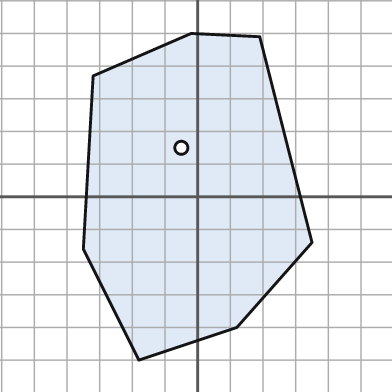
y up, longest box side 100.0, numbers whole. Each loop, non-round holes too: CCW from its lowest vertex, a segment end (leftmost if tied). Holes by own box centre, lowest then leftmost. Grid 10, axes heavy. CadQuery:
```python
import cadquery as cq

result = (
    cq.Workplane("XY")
    .moveTo(-18.0, -50.0)
    .lineTo(12.0, -40.0)
    .lineTo(35.0, -14.0)
    .lineTo(19.0, 49.0)
    .lineTo(-2.0, 50.0)
    .lineTo(-32.0, 37.0)
    .lineTo(-35.0, -16.0)
    .close()
    .moveTo(-5.0, 15.0)
    .circle(2.0)
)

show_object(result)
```